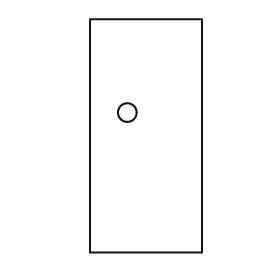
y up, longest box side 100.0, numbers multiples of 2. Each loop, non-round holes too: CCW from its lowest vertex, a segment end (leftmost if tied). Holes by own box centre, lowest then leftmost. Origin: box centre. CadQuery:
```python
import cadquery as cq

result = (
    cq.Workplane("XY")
    .moveTo(-24.0, -50.0)
    .lineTo(24.0, -50.0)
    .lineTo(24.0, 50.0)
    .lineTo(-24.0, 50.0)
    .close()
    .moveTo(-8.0, 10.0)
    .circle(4.0)
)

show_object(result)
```